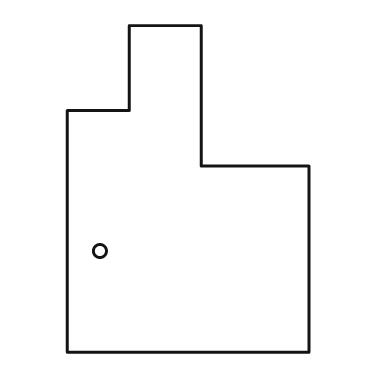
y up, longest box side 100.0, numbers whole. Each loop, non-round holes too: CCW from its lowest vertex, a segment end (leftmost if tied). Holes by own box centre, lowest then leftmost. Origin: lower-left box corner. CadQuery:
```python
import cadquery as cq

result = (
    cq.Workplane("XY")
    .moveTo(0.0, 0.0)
    .lineTo(74.0, 0.0)
    .lineTo(74.0, 57.0)
    .lineTo(41.0, 57.0)
    .lineTo(41.0, 100.0)
    .lineTo(19.0, 100.0)
    .lineTo(19.0, 74.0)
    .lineTo(0.0, 74.0)
    .close()
    .moveTo(10.0, 31.0)
    .circle(2.0)
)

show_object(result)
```